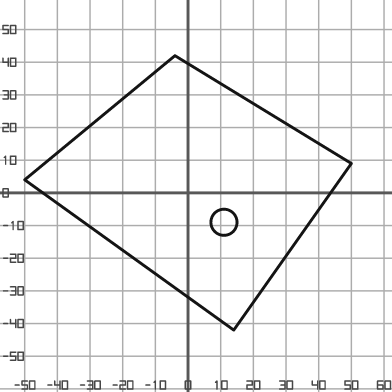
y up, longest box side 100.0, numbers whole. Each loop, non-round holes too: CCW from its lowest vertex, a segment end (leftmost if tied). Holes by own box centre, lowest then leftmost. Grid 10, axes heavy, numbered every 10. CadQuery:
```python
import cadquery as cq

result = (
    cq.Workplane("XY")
    .moveTo(14.0, -42.0)
    .lineTo(50.0, 9.0)
    .lineTo(-4.0, 42.0)
    .lineTo(-50.0, 4.0)
    .close()
    .moveTo(11.0, -9.0)
    .circle(4.0)
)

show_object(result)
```